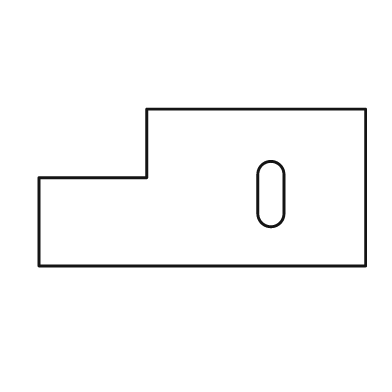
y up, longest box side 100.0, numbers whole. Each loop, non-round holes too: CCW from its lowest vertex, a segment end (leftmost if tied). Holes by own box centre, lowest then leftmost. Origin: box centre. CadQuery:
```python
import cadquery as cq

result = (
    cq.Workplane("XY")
    .moveTo(-50.0, -24.0)
    .lineTo(50.0, -24.0)
    .lineTo(50.0, 24.0)
    .lineTo(-17.0, 24.0)
    .lineTo(-17.0, 3.0)
    .lineTo(-50.0, 3.0)
    .close()
    .moveTo(17.0, -8.0)
    .threePointArc((21.0, -12.0), (25.0, -8.0))
    .lineTo(25.0, 4.0)
    .threePointArc((21.0, 8.0), (17.0, 4.0))
    .close()
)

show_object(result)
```